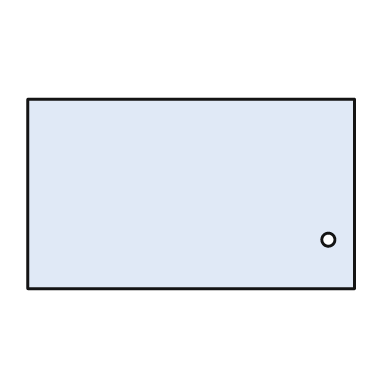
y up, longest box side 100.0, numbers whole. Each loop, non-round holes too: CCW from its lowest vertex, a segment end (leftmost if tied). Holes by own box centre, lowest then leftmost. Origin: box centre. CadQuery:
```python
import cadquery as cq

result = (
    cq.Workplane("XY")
    .moveTo(-50.0, -29.0)
    .lineTo(50.0, -29.0)
    .lineTo(50.0, 29.0)
    .lineTo(-50.0, 29.0)
    .close()
    .moveTo(42.0, -14.0)
    .circle(2.0)
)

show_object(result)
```